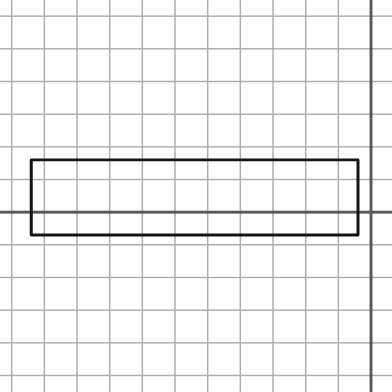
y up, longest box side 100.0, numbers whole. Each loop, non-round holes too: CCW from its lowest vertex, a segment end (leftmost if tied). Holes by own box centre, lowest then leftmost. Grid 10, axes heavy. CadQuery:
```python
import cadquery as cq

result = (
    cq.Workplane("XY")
    .moveTo(-104.0, -7.0)
    .lineTo(-4.0, -7.0)
    .lineTo(-4.0, 16.0)
    .lineTo(-104.0, 16.0)
    .close()
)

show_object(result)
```